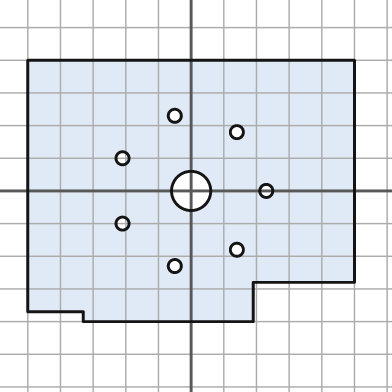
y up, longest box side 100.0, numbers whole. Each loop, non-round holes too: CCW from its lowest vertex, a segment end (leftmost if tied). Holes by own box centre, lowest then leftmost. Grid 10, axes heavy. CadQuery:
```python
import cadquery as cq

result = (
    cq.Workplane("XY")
    .moveTo(-33.0, -40.0)
    .lineTo(19.0, -40.0)
    .lineTo(19.0, -28.0)
    .lineTo(50.0, -28.0)
    .lineTo(50.0, 40.0)
    .lineTo(-50.0, 40.0)
    .lineTo(-50.0, -37.0)
    .lineTo(-33.0, -37.0)
    .close()
    .moveTo(-5.0, -23.0)
    .circle(2.0)
    .moveTo(14.0, -18.0)
    .circle(2.0)
    .moveTo(-21.0, -10.0)
    .circle(2.0)
    .moveTo(0.0, 0.0)
    .circle(6.0)
    .moveTo(23.0, 0.0)
    .circle(2.0)
    .moveTo(-21.0, 10.0)
    .circle(2.0)
    .moveTo(14.0, 18.0)
    .circle(2.0)
    .moveTo(-5.0, 23.0)
    .circle(2.0)
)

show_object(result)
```